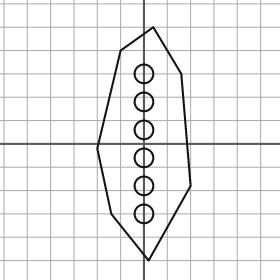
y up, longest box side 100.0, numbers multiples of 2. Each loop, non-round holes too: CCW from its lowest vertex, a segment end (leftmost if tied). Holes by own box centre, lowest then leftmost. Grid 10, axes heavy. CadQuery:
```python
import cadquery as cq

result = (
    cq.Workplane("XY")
    .moveTo(2.0, -50.0)
    .lineTo(20.0, -18.0)
    .lineTo(16.0, 30.0)
    .lineTo(4.0, 50.0)
    .lineTo(-10.0, 40.0)
    .lineTo(-20.0, -2.0)
    .lineTo(-14.0, -30.0)
    .close()
    .moveTo(0.0, -30.0)
    .circle(4.0)
    .moveTo(0.0, -18.0)
    .circle(4.0)
    .moveTo(0.0, -6.0)
    .circle(4.0)
    .moveTo(0.0, 6.0)
    .circle(4.0)
    .moveTo(0.0, 18.0)
    .circle(4.0)
    .moveTo(0.0, 30.0)
    .circle(4.0)
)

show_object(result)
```